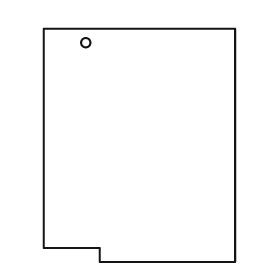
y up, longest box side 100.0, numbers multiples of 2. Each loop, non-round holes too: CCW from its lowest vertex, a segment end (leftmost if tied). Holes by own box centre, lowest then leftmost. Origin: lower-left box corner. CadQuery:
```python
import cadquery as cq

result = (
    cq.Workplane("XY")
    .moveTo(24.0, 0.0)
    .lineTo(82.0, 0.0)
    .lineTo(82.0, 100.0)
    .lineTo(0.0, 100.0)
    .lineTo(0.0, 6.0)
    .lineTo(24.0, 6.0)
    .close()
    .moveTo(18.0, 94.0)
    .circle(2.0)
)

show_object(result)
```